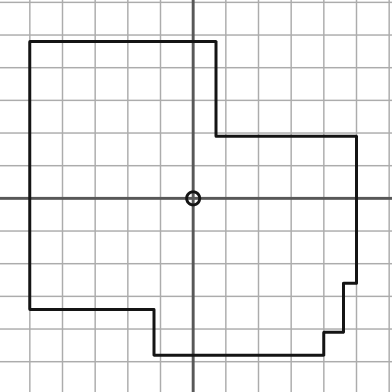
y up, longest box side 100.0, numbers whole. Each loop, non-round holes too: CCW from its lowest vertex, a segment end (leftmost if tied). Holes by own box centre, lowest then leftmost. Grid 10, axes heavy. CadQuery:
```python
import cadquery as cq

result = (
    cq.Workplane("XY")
    .moveTo(-12.0, -48.0)
    .lineTo(40.0, -48.0)
    .lineTo(40.0, -41.0)
    .lineTo(46.0, -41.0)
    .lineTo(46.0, -26.0)
    .lineTo(50.0, -26.0)
    .lineTo(50.0, 19.0)
    .lineTo(7.0, 19.0)
    .lineTo(7.0, 48.0)
    .lineTo(-50.0, 48.0)
    .lineTo(-50.0, -34.0)
    .lineTo(-12.0, -34.0)
    .close()
    .moveTo(0.0, 0.0)
    .circle(2.0)
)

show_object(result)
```